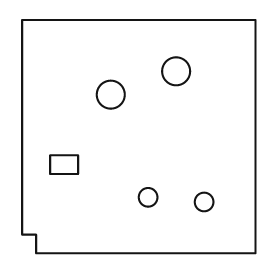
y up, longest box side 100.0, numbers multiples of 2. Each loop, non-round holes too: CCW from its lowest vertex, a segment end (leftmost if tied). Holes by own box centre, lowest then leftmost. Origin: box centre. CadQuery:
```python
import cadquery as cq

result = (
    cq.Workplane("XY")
    .moveTo(-44.0, -50.0)
    .lineTo(50.0, -50.0)
    .lineTo(50.0, 50.0)
    .lineTo(-50.0, 50.0)
    .lineTo(-50.0, -42.0)
    .lineTo(-44.0, -42.0)
    .close()
    .moveTo(28.0, -28.0)
    .circle(4.0)
    .moveTo(4.0, -26.0)
    .circle(4.0)
    .moveTo(-38.0, -16.0)
    .lineTo(-26.0, -16.0)
    .lineTo(-26.0, -8.0)
    .lineTo(-38.0, -8.0)
    .close()
    .moveTo(-12.0, 18.0)
    .circle(6.0)
    .moveTo(16.0, 28.0)
    .circle(6.0)
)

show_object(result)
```